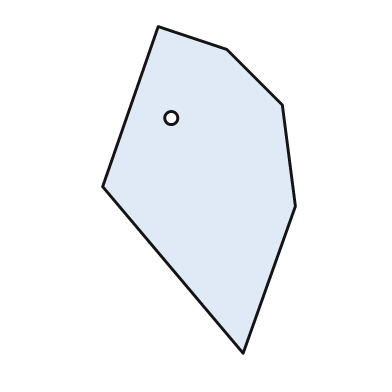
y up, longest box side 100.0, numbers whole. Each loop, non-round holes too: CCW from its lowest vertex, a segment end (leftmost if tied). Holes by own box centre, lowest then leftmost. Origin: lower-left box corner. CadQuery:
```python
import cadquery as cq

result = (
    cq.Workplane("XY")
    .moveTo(43.0, 0.0)
    .lineTo(59.0, 45.0)
    .lineTo(55.0, 76.0)
    .lineTo(38.0, 93.0)
    .lineTo(17.0, 100.0)
    .lineTo(0.0, 51.0)
    .close()
    .moveTo(21.0, 72.0)
    .circle(2.0)
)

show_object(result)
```